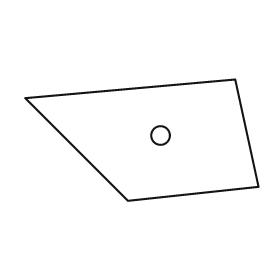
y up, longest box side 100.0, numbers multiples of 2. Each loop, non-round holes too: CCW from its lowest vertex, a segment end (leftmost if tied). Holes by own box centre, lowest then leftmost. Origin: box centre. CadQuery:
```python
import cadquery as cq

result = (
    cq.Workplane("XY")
    .moveTo(-6.0, -26.0)
    .lineTo(50.0, -20.0)
    .lineTo(40.0, 26.0)
    .lineTo(-50.0, 18.0)
    .close()
    .moveTo(8.0, 2.0)
    .circle(4.0)
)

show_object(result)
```